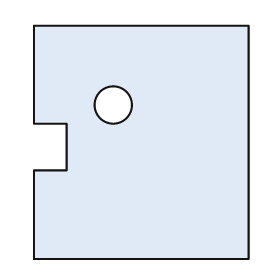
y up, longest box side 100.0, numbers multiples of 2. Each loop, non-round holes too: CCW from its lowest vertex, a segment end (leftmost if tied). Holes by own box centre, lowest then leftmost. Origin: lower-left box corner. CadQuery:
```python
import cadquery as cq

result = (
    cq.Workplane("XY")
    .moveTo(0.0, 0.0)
    .lineTo(92.0, 0.0)
    .lineTo(92.0, 100.0)
    .lineTo(0.0, 100.0)
    .lineTo(0.0, 58.0)
    .lineTo(14.0, 58.0)
    .lineTo(14.0, 38.0)
    .lineTo(0.0, 38.0)
    .close()
    .moveTo(34.0, 66.0)
    .circle(8.0)
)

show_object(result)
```